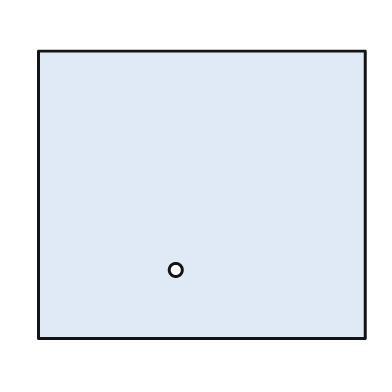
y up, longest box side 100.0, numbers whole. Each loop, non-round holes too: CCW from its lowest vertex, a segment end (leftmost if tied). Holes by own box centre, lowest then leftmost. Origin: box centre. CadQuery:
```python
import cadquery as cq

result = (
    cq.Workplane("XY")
    .moveTo(-50.0, -44.0)
    .lineTo(50.0, -44.0)
    .lineTo(50.0, 44.0)
    .lineTo(-50.0, 44.0)
    .close()
    .moveTo(-8.0, -23.0)
    .circle(2.0)
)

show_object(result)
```